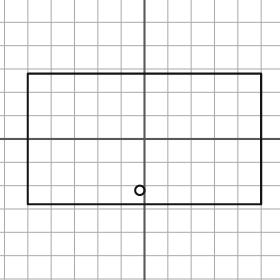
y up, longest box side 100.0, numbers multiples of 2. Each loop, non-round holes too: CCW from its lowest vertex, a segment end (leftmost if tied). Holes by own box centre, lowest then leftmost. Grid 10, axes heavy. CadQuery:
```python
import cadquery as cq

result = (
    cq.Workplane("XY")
    .moveTo(-50.0, -28.0)
    .lineTo(50.0, -28.0)
    .lineTo(50.0, 28.0)
    .lineTo(-50.0, 28.0)
    .close()
    .moveTo(-2.0, -22.0)
    .circle(2.0)
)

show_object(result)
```